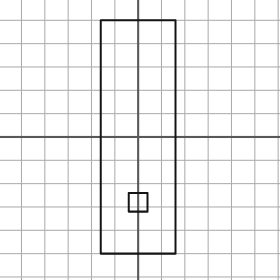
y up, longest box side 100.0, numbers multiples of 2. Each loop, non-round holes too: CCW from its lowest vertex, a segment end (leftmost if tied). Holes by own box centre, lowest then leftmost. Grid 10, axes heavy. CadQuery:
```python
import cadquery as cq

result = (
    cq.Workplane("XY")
    .moveTo(-16.0, -50.0)
    .lineTo(16.0, -50.0)
    .lineTo(16.0, 50.0)
    .lineTo(-16.0, 50.0)
    .close()
    .moveTo(-4.0, -32.0)
    .lineTo(4.0, -32.0)
    .lineTo(4.0, -24.0)
    .lineTo(-4.0, -24.0)
    .close()
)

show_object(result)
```